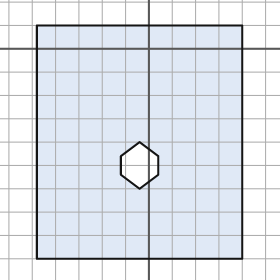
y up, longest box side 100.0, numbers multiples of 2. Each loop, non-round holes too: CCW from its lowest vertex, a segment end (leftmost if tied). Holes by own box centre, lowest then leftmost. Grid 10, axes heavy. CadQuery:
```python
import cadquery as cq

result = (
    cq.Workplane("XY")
    .moveTo(-48.0, -90.0)
    .lineTo(40.0, -90.0)
    .lineTo(40.0, 10.0)
    .lineTo(-48.0, 10.0)
    .close()
    .moveTo(-4.0, -60.0)
    .lineTo(4.0, -54.0)
    .lineTo(4.0, -46.0)
    .lineTo(-4.0, -40.0)
    .lineTo(-12.0, -46.0)
    .lineTo(-12.0, -54.0)
    .close()
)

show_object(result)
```